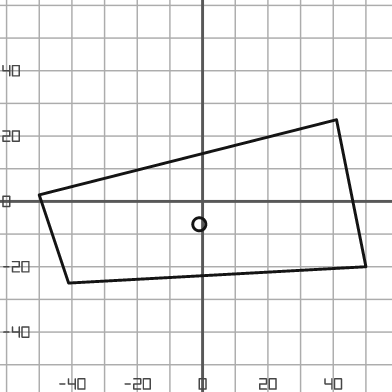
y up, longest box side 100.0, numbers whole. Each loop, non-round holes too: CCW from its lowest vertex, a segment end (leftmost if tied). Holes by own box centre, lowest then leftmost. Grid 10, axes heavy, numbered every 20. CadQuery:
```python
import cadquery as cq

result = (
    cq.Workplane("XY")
    .moveTo(-41.0, -25.0)
    .lineTo(50.0, -20.0)
    .lineTo(41.0, 25.0)
    .lineTo(-50.0, 2.0)
    .close()
    .moveTo(-1.0, -7.0)
    .circle(2.0)
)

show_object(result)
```